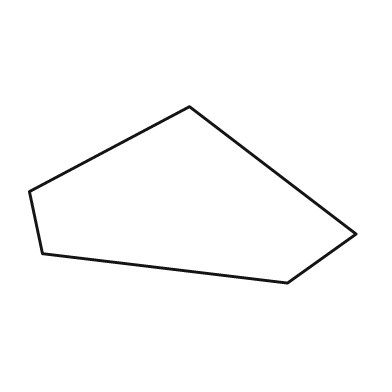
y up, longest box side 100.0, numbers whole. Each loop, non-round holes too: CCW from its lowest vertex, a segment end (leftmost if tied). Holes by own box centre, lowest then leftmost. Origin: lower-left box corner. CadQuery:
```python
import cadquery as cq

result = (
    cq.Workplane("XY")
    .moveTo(79.0, 0.0)
    .lineTo(100.0, 15.0)
    .lineTo(49.0, 54.0)
    .lineTo(0.0, 28.0)
    .lineTo(4.0, 9.0)
    .close()
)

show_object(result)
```